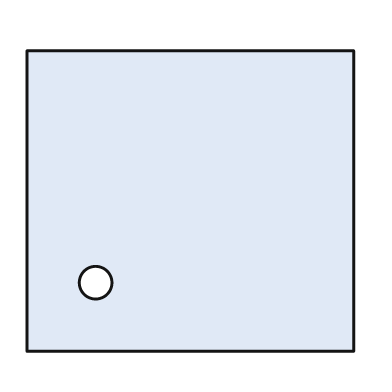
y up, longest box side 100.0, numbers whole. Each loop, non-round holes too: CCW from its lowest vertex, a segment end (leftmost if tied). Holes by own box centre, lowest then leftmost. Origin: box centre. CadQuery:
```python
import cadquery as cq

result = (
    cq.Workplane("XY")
    .moveTo(-50.0, -46.0)
    .lineTo(50.0, -46.0)
    .lineTo(50.0, 46.0)
    .lineTo(-50.0, 46.0)
    .close()
    .moveTo(-29.0, -25.0)
    .circle(5.0)
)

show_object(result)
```